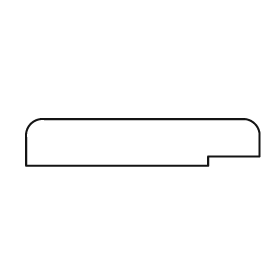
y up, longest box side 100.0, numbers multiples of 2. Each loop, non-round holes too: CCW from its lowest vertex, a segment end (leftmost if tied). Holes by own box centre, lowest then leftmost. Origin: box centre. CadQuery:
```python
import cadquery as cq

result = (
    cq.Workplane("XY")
    .moveTo(-50.0, -10.0)
    .lineTo(28.0, -10.0)
    .lineTo(28.0, -6.0)
    .lineTo(50.0, -6.0)
    .lineTo(50.0, 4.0)
    .threePointArc((48.0, 8.0), (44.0, 10.0))
    .lineTo(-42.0, 10.0)
    .threePointArc((-48.0, 8.0), (-50.0, 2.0))
    .close()
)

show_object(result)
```